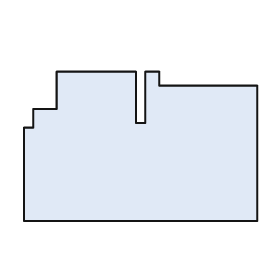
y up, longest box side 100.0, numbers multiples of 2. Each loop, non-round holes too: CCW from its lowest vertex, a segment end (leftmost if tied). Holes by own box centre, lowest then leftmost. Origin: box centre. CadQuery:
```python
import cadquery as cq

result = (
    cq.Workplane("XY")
    .moveTo(-50.0, -32.0)
    .lineTo(50.0, -32.0)
    .lineTo(50.0, 26.0)
    .lineTo(8.0, 26.0)
    .lineTo(8.0, 32.0)
    .lineTo(2.0, 32.0)
    .lineTo(2.0, 10.0)
    .lineTo(-2.0, 10.0)
    .lineTo(-2.0, 32.0)
    .lineTo(-36.0, 32.0)
    .lineTo(-36.0, 16.0)
    .lineTo(-46.0, 16.0)
    .lineTo(-46.0, 8.0)
    .lineTo(-50.0, 8.0)
    .close()
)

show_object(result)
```